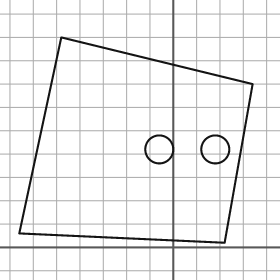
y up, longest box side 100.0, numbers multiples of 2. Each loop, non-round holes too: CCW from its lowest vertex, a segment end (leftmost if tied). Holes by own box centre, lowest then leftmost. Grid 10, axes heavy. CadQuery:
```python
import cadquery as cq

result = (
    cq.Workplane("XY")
    .moveTo(22.0, 2.0)
    .lineTo(34.0, 70.0)
    .lineTo(-48.0, 90.0)
    .lineTo(-66.0, 6.0)
    .close()
    .moveTo(-6.0, 42.0)
    .circle(6.0)
    .moveTo(18.0, 42.0)
    .circle(6.0)
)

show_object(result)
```